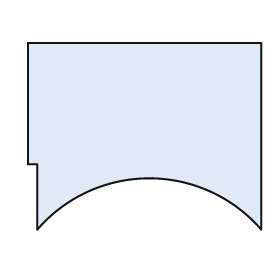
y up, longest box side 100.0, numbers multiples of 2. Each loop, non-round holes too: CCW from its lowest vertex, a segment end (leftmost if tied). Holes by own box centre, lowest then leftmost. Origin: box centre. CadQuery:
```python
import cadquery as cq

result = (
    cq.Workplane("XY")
    .moveTo(-46.0, -40.0)
    .threePointArc((2.0, -18.0), (50.0, -40.0))
    .lineTo(50.0, 40.0)
    .lineTo(-50.0, 40.0)
    .lineTo(-50.0, -12.0)
    .lineTo(-46.0, -12.0)
    .close()
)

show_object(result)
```